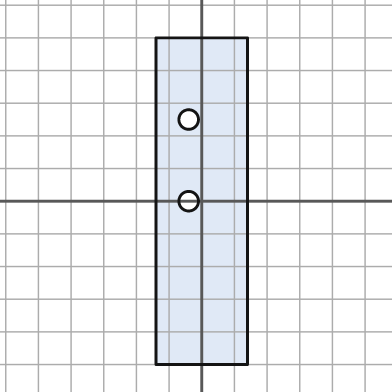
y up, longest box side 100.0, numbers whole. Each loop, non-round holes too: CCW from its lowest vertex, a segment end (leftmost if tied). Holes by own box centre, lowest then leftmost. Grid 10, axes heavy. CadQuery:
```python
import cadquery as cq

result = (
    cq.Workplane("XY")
    .moveTo(-14.0, -50.0)
    .lineTo(14.0, -50.0)
    .lineTo(14.0, 50.0)
    .lineTo(-14.0, 50.0)
    .close()
    .moveTo(-4.0, 0.0)
    .circle(3.0)
    .moveTo(-4.0, 25.0)
    .circle(3.0)
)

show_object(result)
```